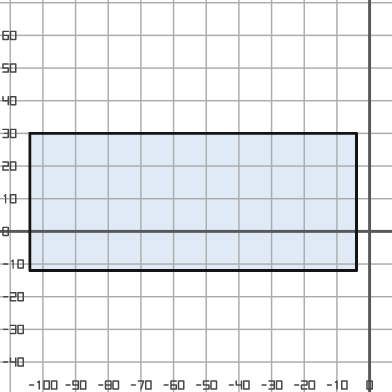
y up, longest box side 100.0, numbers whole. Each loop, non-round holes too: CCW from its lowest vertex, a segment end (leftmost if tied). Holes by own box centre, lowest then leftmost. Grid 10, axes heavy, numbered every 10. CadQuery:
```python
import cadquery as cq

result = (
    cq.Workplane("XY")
    .moveTo(-104.0, -12.0)
    .lineTo(-4.0, -12.0)
    .lineTo(-4.0, 30.0)
    .lineTo(-104.0, 30.0)
    .close()
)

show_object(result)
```